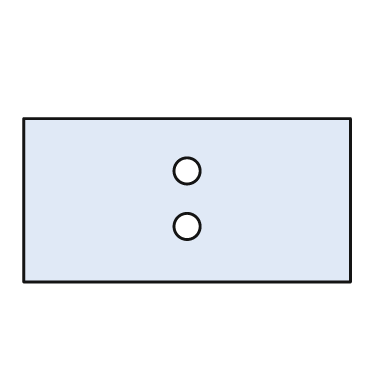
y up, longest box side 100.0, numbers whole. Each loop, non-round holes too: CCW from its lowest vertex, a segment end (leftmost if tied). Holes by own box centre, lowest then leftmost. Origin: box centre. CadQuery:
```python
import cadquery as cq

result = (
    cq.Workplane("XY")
    .moveTo(-50.0, -25.0)
    .lineTo(50.0, -25.0)
    .lineTo(50.0, 25.0)
    .lineTo(-50.0, 25.0)
    .close()
    .moveTo(0.0, -8.0)
    .circle(4.0)
    .moveTo(0.0, 9.0)
    .circle(4.0)
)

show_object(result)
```